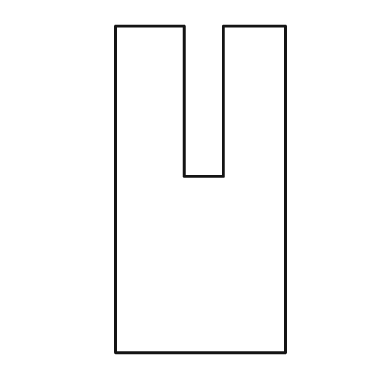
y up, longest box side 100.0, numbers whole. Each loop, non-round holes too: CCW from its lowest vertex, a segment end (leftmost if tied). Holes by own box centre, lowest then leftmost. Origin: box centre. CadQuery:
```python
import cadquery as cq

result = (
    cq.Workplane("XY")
    .moveTo(-26.0, -50.0)
    .lineTo(26.0, -50.0)
    .lineTo(26.0, 50.0)
    .lineTo(7.0, 50.0)
    .lineTo(7.0, 4.0)
    .lineTo(-5.0, 4.0)
    .lineTo(-5.0, 50.0)
    .lineTo(-26.0, 50.0)
    .close()
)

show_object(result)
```